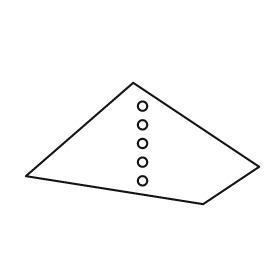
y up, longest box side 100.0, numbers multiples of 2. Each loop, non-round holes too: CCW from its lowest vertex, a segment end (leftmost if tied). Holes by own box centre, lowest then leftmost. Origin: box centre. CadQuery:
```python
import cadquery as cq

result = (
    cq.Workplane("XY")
    .moveTo(26.0, -26.0)
    .lineTo(50.0, -10.0)
    .lineTo(-4.0, 26.0)
    .lineTo(-50.0, -14.0)
    .close()
    .moveTo(0.0, -16.0)
    .circle(2.0)
    .moveTo(0.0, -8.0)
    .circle(2.0)
    .moveTo(0.0, 0.0)
    .circle(2.0)
    .moveTo(0.0, 8.0)
    .circle(2.0)
    .moveTo(0.0, 16.0)
    .circle(2.0)
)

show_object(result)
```